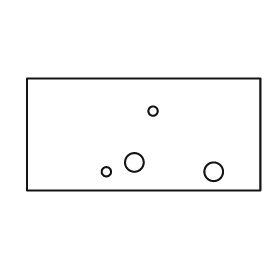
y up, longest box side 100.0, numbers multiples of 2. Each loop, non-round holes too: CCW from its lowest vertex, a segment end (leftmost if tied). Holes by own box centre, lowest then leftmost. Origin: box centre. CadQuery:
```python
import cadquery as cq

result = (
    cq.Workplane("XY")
    .moveTo(-50.0, -24.0)
    .lineTo(50.0, -24.0)
    .lineTo(50.0, 24.0)
    .lineTo(-50.0, 24.0)
    .close()
    .moveTo(-16.0, -16.0)
    .circle(2.0)
    .moveTo(30.0, -16.0)
    .circle(4.0)
    .moveTo(-4.0, -12.0)
    .circle(4.0)
    .moveTo(4.0, 10.0)
    .circle(2.0)
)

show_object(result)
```